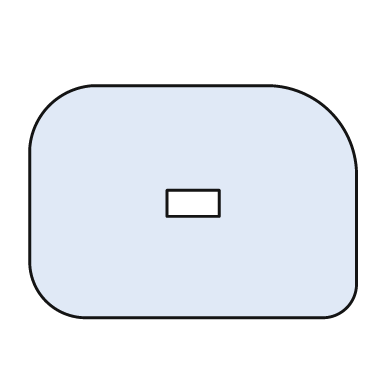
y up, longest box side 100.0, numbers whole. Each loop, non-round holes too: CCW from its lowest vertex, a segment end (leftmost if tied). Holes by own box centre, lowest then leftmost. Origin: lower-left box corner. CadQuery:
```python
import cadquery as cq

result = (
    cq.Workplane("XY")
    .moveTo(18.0, 0.0)
    .lineTo(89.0, 0.0)
    .threePointArc((97.0, 3.0), (100.0, 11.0))
    .lineTo(100.0, 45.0)
    .threePointArc((92.0, 63.0), (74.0, 71.0))
    .lineTo(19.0, 71.0)
    .threePointArc((6.0, 65.0), (0.0, 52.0))
    .lineTo(0.0, 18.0)
    .threePointArc((5.0, 5.0), (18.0, 0.0))
    .close()
    .moveTo(42.0, 31.0)
    .lineTo(58.0, 31.0)
    .lineTo(58.0, 39.0)
    .lineTo(42.0, 39.0)
    .close()
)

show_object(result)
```